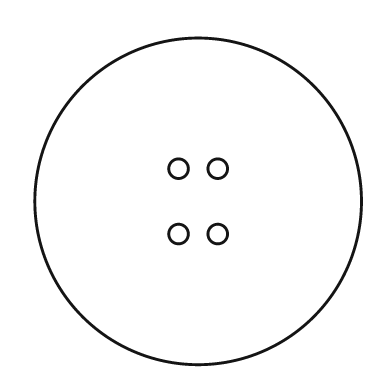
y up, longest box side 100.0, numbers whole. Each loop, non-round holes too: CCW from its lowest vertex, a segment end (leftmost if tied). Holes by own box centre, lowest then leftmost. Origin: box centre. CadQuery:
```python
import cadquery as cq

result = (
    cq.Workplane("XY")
    .moveTo(0.0, 0.0)
    .circle(50.0)
    .moveTo(-6.0, -10.0)
    .circle(3.0)
    .moveTo(6.0, -10.0)
    .circle(3.0)
    .moveTo(-6.0, 10.0)
    .circle(3.0)
    .moveTo(6.0, 10.0)
    .circle(3.0)
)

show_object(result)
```